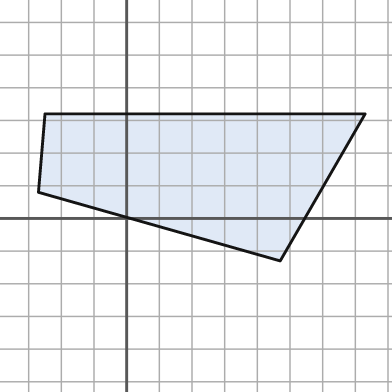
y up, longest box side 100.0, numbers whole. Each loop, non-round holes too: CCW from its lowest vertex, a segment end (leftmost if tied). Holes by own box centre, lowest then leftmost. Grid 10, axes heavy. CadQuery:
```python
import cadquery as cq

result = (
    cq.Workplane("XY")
    .moveTo(47.0, -13.0)
    .lineTo(73.0, 32.0)
    .lineTo(-25.0, 32.0)
    .lineTo(-27.0, 8.0)
    .close()
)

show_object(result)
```